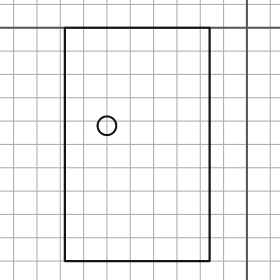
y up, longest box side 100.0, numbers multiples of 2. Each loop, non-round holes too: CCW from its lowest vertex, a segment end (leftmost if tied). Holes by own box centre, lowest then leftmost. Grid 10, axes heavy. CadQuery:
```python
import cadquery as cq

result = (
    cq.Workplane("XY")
    .moveTo(-78.0, -100.0)
    .lineTo(-16.0, -100.0)
    .lineTo(-16.0, 0.0)
    .lineTo(-78.0, 0.0)
    .close()
    .moveTo(-60.0, -42.0)
    .circle(4.0)
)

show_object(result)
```